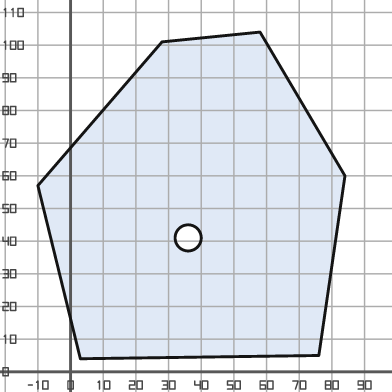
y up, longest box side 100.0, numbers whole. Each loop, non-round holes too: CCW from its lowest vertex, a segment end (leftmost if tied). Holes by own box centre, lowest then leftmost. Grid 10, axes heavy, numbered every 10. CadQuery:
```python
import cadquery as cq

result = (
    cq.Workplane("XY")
    .moveTo(3.0, 4.0)
    .lineTo(76.0, 5.0)
    .lineTo(84.0, 60.0)
    .lineTo(58.0, 104.0)
    .lineTo(28.0, 101.0)
    .lineTo(-10.0, 57.0)
    .close()
    .moveTo(36.0, 41.0)
    .circle(4.0)
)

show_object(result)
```